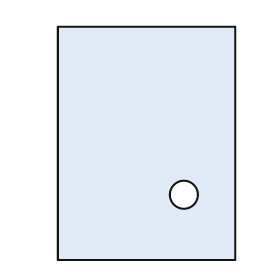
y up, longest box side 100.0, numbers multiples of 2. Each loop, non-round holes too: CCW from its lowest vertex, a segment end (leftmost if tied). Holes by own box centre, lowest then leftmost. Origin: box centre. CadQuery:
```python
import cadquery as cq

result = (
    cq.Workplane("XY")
    .moveTo(-38.0, -50.0)
    .lineTo(38.0, -50.0)
    .lineTo(38.0, 50.0)
    .lineTo(-38.0, 50.0)
    .close()
    .moveTo(16.0, -22.0)
    .circle(6.0)
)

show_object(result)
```